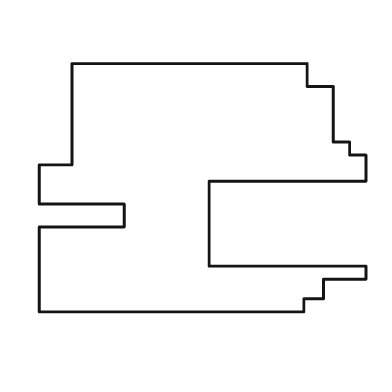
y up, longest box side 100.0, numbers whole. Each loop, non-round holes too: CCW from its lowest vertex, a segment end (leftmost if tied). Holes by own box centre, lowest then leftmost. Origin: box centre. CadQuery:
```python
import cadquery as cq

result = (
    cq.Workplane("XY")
    .moveTo(-50.0, -38.0)
    .lineTo(31.0, -38.0)
    .lineTo(31.0, -34.0)
    .lineTo(37.0, -34.0)
    .lineTo(37.0, -28.0)
    .lineTo(50.0, -28.0)
    .lineTo(50.0, -24.0)
    .lineTo(2.0, -24.0)
    .lineTo(2.0, 2.0)
    .lineTo(50.0, 2.0)
    .lineTo(50.0, 10.0)
    .lineTo(45.0, 10.0)
    .lineTo(45.0, 14.0)
    .lineTo(40.0, 14.0)
    .lineTo(40.0, 31.0)
    .lineTo(32.0, 31.0)
    .lineTo(32.0, 38.0)
    .lineTo(-40.0, 38.0)
    .lineTo(-40.0, 7.0)
    .lineTo(-50.0, 7.0)
    .lineTo(-50.0, -5.0)
    .lineTo(-24.0, -5.0)
    .lineTo(-24.0, -12.0)
    .lineTo(-50.0, -12.0)
    .close()
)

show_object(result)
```